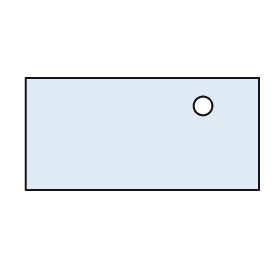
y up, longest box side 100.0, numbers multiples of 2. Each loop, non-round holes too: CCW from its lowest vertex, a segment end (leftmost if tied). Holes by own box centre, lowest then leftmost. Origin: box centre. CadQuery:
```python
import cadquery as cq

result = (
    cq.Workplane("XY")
    .moveTo(-50.0, -24.0)
    .lineTo(50.0, -24.0)
    .lineTo(50.0, 24.0)
    .lineTo(-50.0, 24.0)
    .close()
    .moveTo(26.0, 12.0)
    .circle(4.0)
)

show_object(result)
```